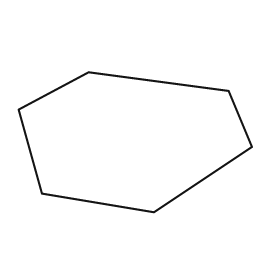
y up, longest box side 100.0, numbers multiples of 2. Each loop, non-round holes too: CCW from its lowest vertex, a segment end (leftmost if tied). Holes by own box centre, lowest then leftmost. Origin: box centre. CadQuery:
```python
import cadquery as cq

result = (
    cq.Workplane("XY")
    .moveTo(8.0, -30.0)
    .lineTo(50.0, -2.0)
    .lineTo(40.0, 22.0)
    .lineTo(-20.0, 30.0)
    .lineTo(-50.0, 14.0)
    .lineTo(-40.0, -22.0)
    .close()
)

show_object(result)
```